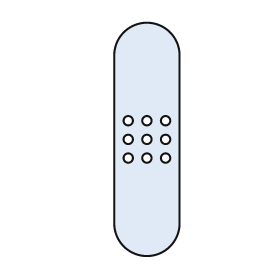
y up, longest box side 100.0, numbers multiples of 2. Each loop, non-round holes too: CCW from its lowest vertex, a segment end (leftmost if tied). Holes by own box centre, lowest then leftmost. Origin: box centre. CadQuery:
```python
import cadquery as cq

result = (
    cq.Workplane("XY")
    .moveTo(-14.0, -36.0)
    .threePointArc((0.0, -50.0), (14.0, -36.0))
    .lineTo(14.0, 36.0)
    .threePointArc((0.0, 50.0), (-14.0, 36.0))
    .close()
    .moveTo(-8.0, -8.0)
    .circle(2.0)
    .moveTo(0.0, -8.0)
    .circle(2.0)
    .moveTo(8.0, -8.0)
    .circle(2.0)
    .moveTo(-8.0, 0.0)
    .circle(2.0)
    .moveTo(0.0, 0.0)
    .circle(2.0)
    .moveTo(8.0, 0.0)
    .circle(2.0)
    .moveTo(-8.0, 8.0)
    .circle(2.0)
    .moveTo(0.0, 8.0)
    .circle(2.0)
    .moveTo(8.0, 8.0)
    .circle(2.0)
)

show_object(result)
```